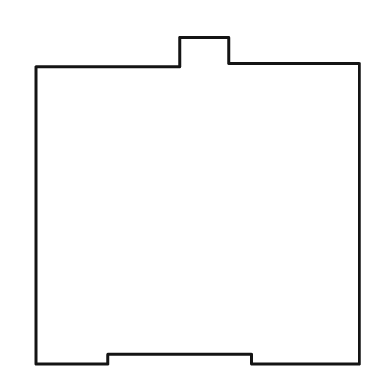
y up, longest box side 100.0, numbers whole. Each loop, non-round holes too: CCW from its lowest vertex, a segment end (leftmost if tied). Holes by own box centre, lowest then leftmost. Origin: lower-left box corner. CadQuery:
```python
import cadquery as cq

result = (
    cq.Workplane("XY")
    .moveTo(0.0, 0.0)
    .lineTo(22.0, 0.0)
    .lineTo(22.0, 3.0)
    .lineTo(66.0, 3.0)
    .lineTo(66.0, 0.0)
    .lineTo(99.0, 0.0)
    .lineTo(99.0, 92.0)
    .lineTo(59.0, 92.0)
    .lineTo(59.0, 100.0)
    .lineTo(44.0, 100.0)
    .lineTo(44.0, 91.0)
    .lineTo(0.0, 91.0)
    .close()
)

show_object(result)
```